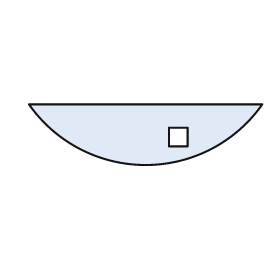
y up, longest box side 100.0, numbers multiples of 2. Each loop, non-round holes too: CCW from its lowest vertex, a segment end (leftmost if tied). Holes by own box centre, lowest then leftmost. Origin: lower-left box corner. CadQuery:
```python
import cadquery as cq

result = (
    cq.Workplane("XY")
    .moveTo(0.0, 26.0)
    .threePointArc((50.0, 0.0), (100.0, 26.0))
    .close()
    .moveTo(60.0, 8.0)
    .lineTo(68.0, 8.0)
    .lineTo(68.0, 16.0)
    .lineTo(60.0, 16.0)
    .close()
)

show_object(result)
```